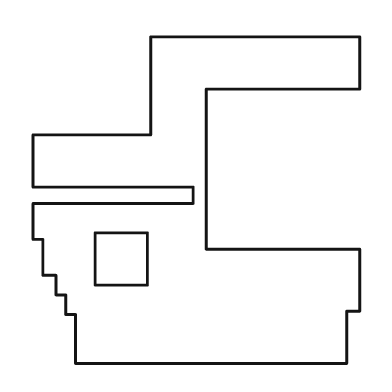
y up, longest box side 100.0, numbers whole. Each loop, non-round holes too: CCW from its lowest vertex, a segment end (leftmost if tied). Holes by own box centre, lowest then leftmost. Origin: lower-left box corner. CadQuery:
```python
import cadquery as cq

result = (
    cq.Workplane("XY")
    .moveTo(13.0, 0.0)
    .lineTo(96.0, 0.0)
    .lineTo(96.0, 16.0)
    .lineTo(100.0, 16.0)
    .lineTo(100.0, 35.0)
    .lineTo(53.0, 35.0)
    .lineTo(53.0, 84.0)
    .lineTo(100.0, 84.0)
    .lineTo(100.0, 100.0)
    .lineTo(36.0, 100.0)
    .lineTo(36.0, 70.0)
    .lineTo(0.0, 70.0)
    .lineTo(0.0, 54.0)
    .lineTo(49.0, 54.0)
    .lineTo(49.0, 49.0)
    .lineTo(0.0, 49.0)
    .lineTo(0.0, 38.0)
    .lineTo(3.0, 38.0)
    .lineTo(3.0, 27.0)
    .lineTo(7.0, 27.0)
    .lineTo(7.0, 21.0)
    .lineTo(10.0, 21.0)
    .lineTo(10.0, 15.0)
    .lineTo(13.0, 15.0)
    .close()
    .moveTo(19.0, 24.0)
    .lineTo(35.0, 24.0)
    .lineTo(35.0, 40.0)
    .lineTo(19.0, 40.0)
    .close()
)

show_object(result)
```